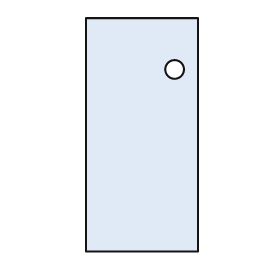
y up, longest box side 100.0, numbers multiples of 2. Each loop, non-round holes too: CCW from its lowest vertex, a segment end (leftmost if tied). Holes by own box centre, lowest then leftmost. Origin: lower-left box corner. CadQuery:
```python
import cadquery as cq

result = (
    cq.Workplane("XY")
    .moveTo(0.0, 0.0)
    .lineTo(48.0, 0.0)
    .lineTo(48.0, 100.0)
    .lineTo(0.0, 100.0)
    .close()
    .moveTo(38.0, 78.0)
    .circle(4.0)
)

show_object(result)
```